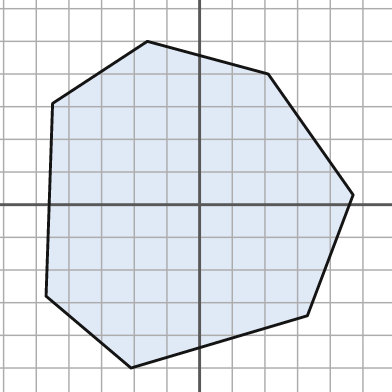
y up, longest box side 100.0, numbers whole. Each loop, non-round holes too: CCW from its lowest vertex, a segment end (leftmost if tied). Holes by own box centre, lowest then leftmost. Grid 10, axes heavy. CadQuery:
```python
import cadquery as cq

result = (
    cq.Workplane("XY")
    .moveTo(-21.0, -50.0)
    .lineTo(33.0, -34.0)
    .lineTo(47.0, 3.0)
    .lineTo(21.0, 40.0)
    .lineTo(-16.0, 50.0)
    .lineTo(-45.0, 31.0)
    .lineTo(-47.0, -28.0)
    .close()
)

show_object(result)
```